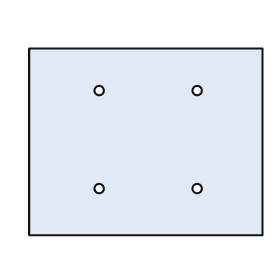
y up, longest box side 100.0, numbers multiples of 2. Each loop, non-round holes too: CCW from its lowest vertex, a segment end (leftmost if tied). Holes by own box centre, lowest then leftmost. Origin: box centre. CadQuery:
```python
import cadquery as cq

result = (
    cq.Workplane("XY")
    .moveTo(-50.0, -40.0)
    .lineTo(50.0, -40.0)
    .lineTo(50.0, 40.0)
    .lineTo(-50.0, 40.0)
    .close()
    .moveTo(-20.0, -20.0)
    .circle(2.0)
    .moveTo(22.0, -20.0)
    .circle(2.0)
    .moveTo(-20.0, 22.0)
    .circle(2.0)
    .moveTo(22.0, 22.0)
    .circle(2.0)
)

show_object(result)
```